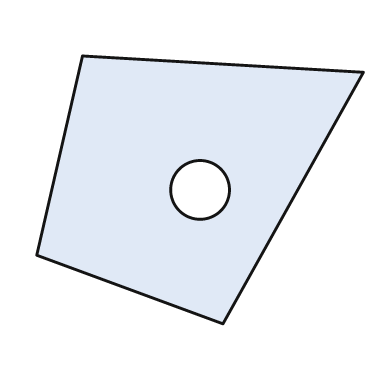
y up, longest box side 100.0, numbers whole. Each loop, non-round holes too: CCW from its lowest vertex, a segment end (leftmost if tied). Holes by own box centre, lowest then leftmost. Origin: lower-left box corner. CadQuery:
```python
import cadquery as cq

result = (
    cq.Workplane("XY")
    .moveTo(57.0, 0.0)
    .lineTo(100.0, 77.0)
    .lineTo(14.0, 82.0)
    .lineTo(0.0, 21.0)
    .close()
    .moveTo(50.0, 41.0)
    .circle(9.0)
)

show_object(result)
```